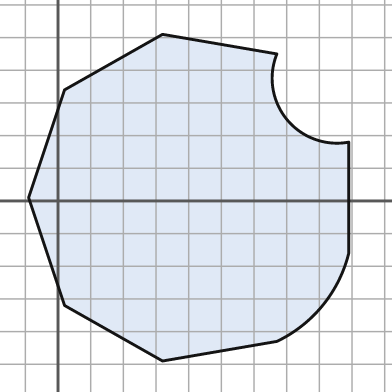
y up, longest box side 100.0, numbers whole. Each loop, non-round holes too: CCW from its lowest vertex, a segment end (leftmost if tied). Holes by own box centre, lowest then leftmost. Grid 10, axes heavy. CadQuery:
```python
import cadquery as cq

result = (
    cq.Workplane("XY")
    .moveTo(32.0, -49.0)
    .lineTo(67.0, -43.0)
    .threePointArc((81.0, -32.0), (89.0, -16.0))
    .lineTo(89.0, 18.0)
    .threePointArc((70.0, 25.0), (67.0, 45.0))
    .lineTo(32.0, 51.0)
    .lineTo(2.0, 34.0)
    .lineTo(-9.0, 1.0)
    .lineTo(2.0, -32.0)
    .close()
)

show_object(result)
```